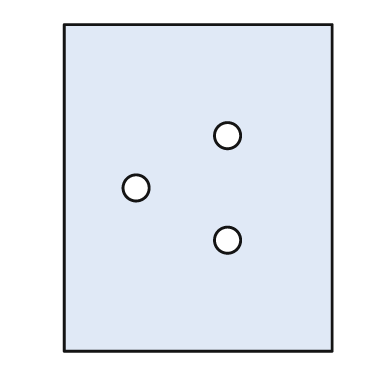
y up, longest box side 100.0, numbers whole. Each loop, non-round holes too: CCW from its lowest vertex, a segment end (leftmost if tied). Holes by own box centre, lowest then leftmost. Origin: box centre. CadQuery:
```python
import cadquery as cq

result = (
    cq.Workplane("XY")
    .moveTo(-41.0, -50.0)
    .lineTo(41.0, -50.0)
    .lineTo(41.0, 50.0)
    .lineTo(-41.0, 50.0)
    .close()
    .moveTo(9.0, -16.0)
    .circle(4.0)
    .moveTo(-19.0, 0.0)
    .circle(4.0)
    .moveTo(9.0, 16.0)
    .circle(4.0)
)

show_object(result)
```